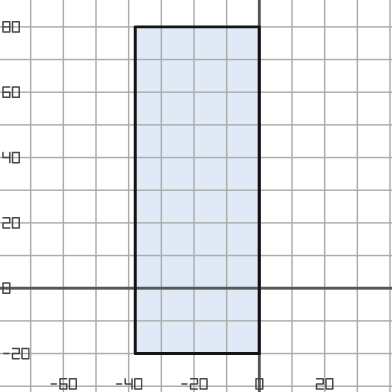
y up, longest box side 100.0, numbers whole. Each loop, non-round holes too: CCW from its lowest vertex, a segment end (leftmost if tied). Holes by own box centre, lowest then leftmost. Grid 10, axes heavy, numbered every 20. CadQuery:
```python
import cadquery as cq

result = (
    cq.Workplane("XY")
    .moveTo(-38.0, -20.0)
    .lineTo(0.0, -20.0)
    .lineTo(0.0, 80.0)
    .lineTo(-38.0, 80.0)
    .close()
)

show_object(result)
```